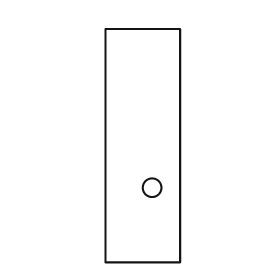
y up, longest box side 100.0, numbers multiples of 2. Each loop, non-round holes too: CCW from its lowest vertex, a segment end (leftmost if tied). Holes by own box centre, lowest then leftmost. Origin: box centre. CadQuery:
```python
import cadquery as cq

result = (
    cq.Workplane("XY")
    .moveTo(-16.0, -50.0)
    .lineTo(16.0, -50.0)
    .lineTo(16.0, 50.0)
    .lineTo(-16.0, 50.0)
    .close()
    .moveTo(4.0, -18.0)
    .circle(4.0)
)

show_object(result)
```